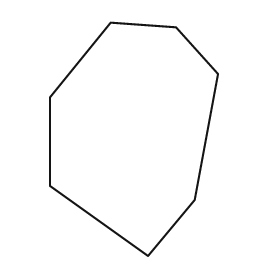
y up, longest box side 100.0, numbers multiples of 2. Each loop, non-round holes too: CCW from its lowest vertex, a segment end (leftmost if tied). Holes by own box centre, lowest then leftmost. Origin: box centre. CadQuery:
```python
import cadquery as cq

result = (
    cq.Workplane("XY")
    .moveTo(6.0, -50.0)
    .lineTo(26.0, -26.0)
    .lineTo(36.0, 28.0)
    .lineTo(18.0, 48.0)
    .lineTo(-10.0, 50.0)
    .lineTo(-36.0, 18.0)
    .lineTo(-36.0, -20.0)
    .close()
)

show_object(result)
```